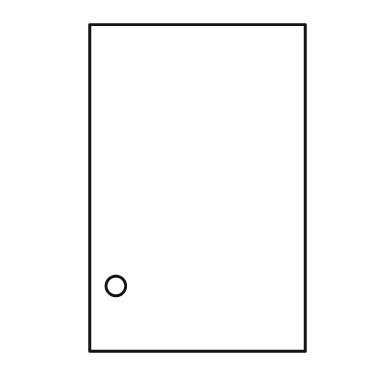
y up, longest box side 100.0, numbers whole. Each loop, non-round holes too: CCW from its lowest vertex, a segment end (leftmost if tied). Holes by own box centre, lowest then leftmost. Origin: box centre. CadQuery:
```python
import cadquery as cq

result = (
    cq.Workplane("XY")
    .moveTo(-33.0, -50.0)
    .lineTo(33.0, -50.0)
    .lineTo(33.0, 50.0)
    .lineTo(-33.0, 50.0)
    .close()
    .moveTo(-25.0, -30.0)
    .circle(3.0)
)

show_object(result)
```